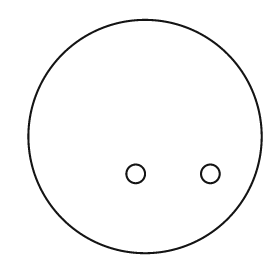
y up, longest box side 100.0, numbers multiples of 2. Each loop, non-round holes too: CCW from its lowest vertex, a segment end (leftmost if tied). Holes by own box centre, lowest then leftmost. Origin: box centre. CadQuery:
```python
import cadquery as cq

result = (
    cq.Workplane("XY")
    .moveTo(0.0, 0.0)
    .circle(50.0)
    .moveTo(-4.0, -16.0)
    .circle(4.0)
    .moveTo(28.0, -16.0)
    .circle(4.0)
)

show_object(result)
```